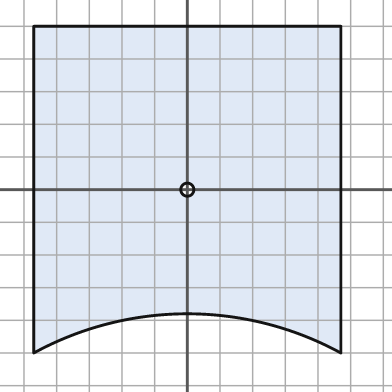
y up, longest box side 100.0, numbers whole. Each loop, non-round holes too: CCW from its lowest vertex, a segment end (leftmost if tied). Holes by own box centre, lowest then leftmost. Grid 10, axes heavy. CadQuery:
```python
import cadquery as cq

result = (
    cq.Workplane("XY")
    .moveTo(-47.0, -50.0)
    .threePointArc((0.0, -38.0), (47.0, -50.0))
    .lineTo(47.0, 50.0)
    .lineTo(-47.0, 50.0)
    .close()
    .moveTo(0.0, 0.0)
    .circle(2.0)
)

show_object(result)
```